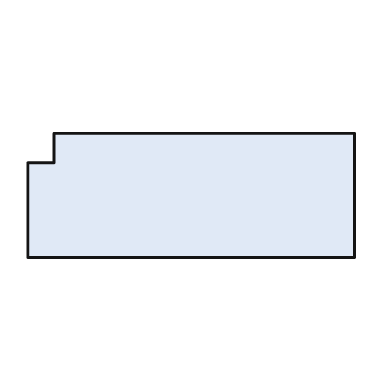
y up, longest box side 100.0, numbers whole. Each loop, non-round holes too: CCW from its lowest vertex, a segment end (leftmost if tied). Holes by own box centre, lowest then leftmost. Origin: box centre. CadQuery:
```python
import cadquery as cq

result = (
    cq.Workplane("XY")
    .moveTo(-50.0, -19.0)
    .lineTo(50.0, -19.0)
    .lineTo(50.0, 19.0)
    .lineTo(-42.0, 19.0)
    .lineTo(-42.0, 10.0)
    .lineTo(-50.0, 10.0)
    .close()
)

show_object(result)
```